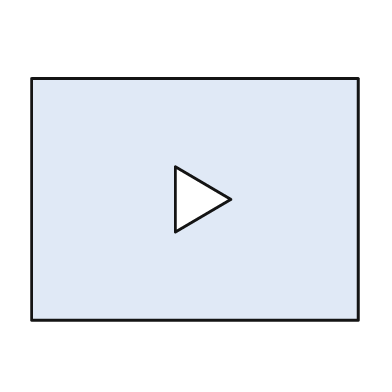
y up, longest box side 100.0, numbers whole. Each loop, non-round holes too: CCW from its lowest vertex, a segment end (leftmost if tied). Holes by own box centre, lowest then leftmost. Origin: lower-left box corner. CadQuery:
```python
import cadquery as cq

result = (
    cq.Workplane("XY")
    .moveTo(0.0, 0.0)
    .lineTo(100.0, 0.0)
    .lineTo(100.0, 74.0)
    .lineTo(0.0, 74.0)
    .close()
    .moveTo(44.0, 27.0)
    .lineTo(61.0, 37.0)
    .lineTo(44.0, 47.0)
    .close()
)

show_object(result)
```